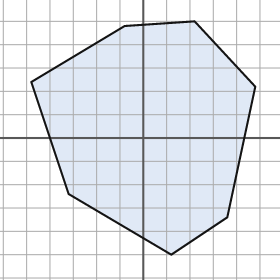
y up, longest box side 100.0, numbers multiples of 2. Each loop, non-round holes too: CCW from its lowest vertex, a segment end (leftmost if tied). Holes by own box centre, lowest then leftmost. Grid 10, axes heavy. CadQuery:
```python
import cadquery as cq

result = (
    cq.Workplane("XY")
    .moveTo(12.0, -50.0)
    .lineTo(36.0, -34.0)
    .lineTo(48.0, 22.0)
    .lineTo(22.0, 50.0)
    .lineTo(-8.0, 48.0)
    .lineTo(-48.0, 24.0)
    .lineTo(-32.0, -24.0)
    .close()
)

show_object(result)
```